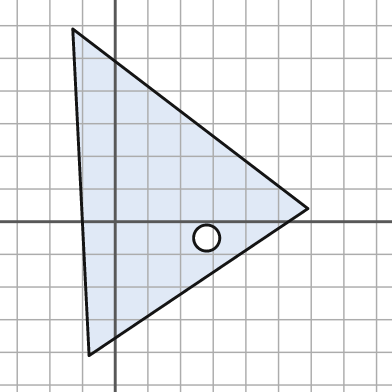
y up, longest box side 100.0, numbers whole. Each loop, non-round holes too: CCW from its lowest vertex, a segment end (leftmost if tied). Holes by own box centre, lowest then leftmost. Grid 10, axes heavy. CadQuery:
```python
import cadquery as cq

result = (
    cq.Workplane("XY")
    .moveTo(-8.0, -41.0)
    .lineTo(59.0, 4.0)
    .lineTo(-13.0, 59.0)
    .close()
    .moveTo(28.0, -5.0)
    .circle(4.0)
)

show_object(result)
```